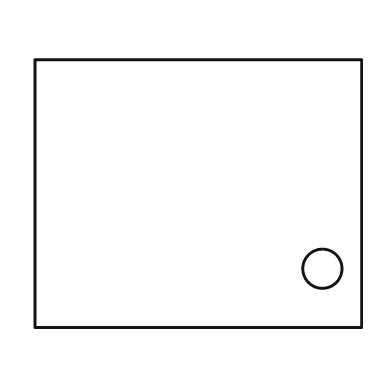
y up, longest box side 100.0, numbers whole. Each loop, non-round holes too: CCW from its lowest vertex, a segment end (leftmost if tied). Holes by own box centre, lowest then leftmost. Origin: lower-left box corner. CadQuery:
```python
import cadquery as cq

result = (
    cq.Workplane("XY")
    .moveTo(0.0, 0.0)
    .lineTo(100.0, 0.0)
    .lineTo(100.0, 82.0)
    .lineTo(0.0, 82.0)
    .close()
    .moveTo(88.0, 18.0)
    .circle(6.0)
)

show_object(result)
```